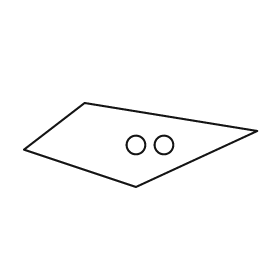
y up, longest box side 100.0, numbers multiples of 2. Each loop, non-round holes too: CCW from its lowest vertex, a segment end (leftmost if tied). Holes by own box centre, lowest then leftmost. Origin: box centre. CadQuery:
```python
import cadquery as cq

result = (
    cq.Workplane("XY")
    .moveTo(-2.0, -18.0)
    .lineTo(50.0, 6.0)
    .lineTo(-24.0, 18.0)
    .lineTo(-50.0, -2.0)
    .close()
    .moveTo(-2.0, 0.0)
    .circle(4.0)
    .moveTo(10.0, 0.0)
    .circle(4.0)
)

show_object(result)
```